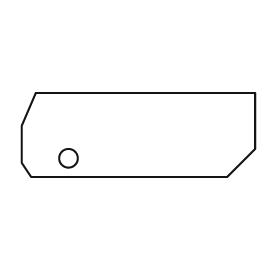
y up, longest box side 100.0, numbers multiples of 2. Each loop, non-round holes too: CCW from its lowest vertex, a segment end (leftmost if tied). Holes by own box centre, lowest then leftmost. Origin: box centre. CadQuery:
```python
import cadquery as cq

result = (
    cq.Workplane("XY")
    .moveTo(-46.0, -18.0)
    .lineTo(38.0, -18.0)
    .lineTo(50.0, -6.0)
    .lineTo(50.0, 18.0)
    .lineTo(-44.0, 18.0)
    .lineTo(-50.0, 4.0)
    .lineTo(-50.0, -12.0)
    .close()
    .moveTo(-30.0, -10.0)
    .circle(4.0)
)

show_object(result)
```